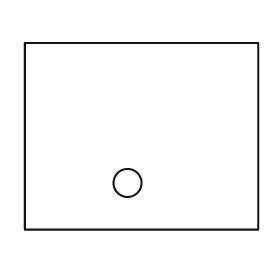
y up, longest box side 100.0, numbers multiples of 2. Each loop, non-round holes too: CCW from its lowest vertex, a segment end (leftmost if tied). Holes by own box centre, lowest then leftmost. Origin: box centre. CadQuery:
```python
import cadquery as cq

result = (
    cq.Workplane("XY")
    .moveTo(-50.0, -40.0)
    .lineTo(50.0, -40.0)
    .lineTo(50.0, 40.0)
    .lineTo(-50.0, 40.0)
    .close()
    .moveTo(-6.0, -20.0)
    .circle(6.0)
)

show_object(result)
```